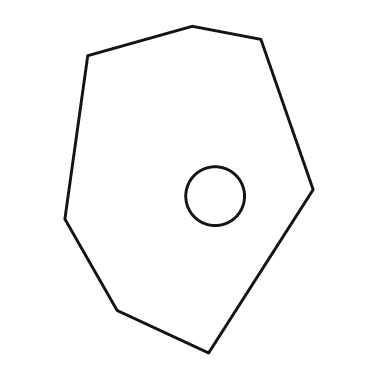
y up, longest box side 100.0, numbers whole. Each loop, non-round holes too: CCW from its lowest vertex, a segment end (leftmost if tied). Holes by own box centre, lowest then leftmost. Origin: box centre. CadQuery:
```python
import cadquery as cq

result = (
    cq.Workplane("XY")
    .moveTo(6.0, -50.0)
    .lineTo(38.0, 0.0)
    .lineTo(22.0, 46.0)
    .lineTo(1.0, 50.0)
    .lineTo(-31.0, 41.0)
    .lineTo(-38.0, -9.0)
    .lineTo(-22.0, -37.0)
    .close()
    .moveTo(8.0, -2.0)
    .circle(9.0)
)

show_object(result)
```